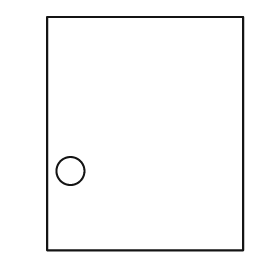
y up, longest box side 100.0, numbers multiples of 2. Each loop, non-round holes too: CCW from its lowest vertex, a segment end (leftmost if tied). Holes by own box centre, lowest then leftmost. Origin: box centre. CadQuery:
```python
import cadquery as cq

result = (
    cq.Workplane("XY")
    .moveTo(-42.0, -50.0)
    .lineTo(42.0, -50.0)
    .lineTo(42.0, 50.0)
    .lineTo(-42.0, 50.0)
    .close()
    .moveTo(-32.0, -16.0)
    .circle(6.0)
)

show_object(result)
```